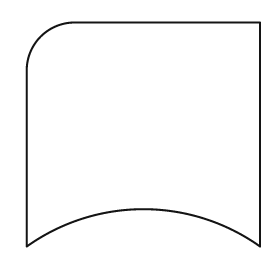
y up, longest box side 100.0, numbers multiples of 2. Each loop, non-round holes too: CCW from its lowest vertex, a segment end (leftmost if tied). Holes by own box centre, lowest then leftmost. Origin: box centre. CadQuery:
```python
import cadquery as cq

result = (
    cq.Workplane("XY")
    .moveTo(-50.0, -48.0)
    .threePointArc((0.0, -32.0), (50.0, -48.0))
    .lineTo(50.0, 48.0)
    .lineTo(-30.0, 48.0)
    .threePointArc((-44.0, 42.0), (-50.0, 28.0))
    .close()
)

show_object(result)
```